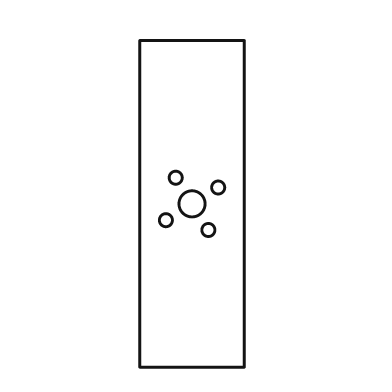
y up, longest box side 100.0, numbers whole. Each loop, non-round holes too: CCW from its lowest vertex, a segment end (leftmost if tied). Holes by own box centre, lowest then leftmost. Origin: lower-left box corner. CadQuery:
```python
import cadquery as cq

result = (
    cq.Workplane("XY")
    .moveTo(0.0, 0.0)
    .lineTo(32.0, 0.0)
    .lineTo(32.0, 100.0)
    .lineTo(0.0, 100.0)
    .close()
    .moveTo(21.0, 42.0)
    .circle(2.0)
    .moveTo(8.0, 45.0)
    .circle(2.0)
    .moveTo(16.0, 50.0)
    .circle(4.0)
    .moveTo(24.0, 55.0)
    .circle(2.0)
    .moveTo(11.0, 58.0)
    .circle(2.0)
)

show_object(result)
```